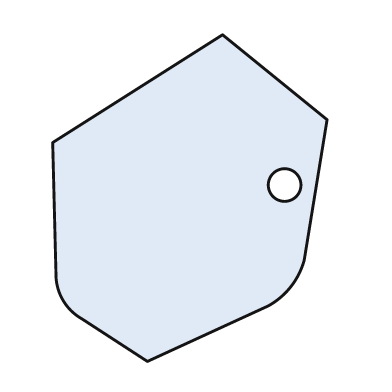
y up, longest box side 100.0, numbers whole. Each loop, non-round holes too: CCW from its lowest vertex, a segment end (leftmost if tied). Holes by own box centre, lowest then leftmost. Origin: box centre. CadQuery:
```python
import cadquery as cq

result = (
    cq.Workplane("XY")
    .moveTo(-13.0, -50.0)
    .lineTo(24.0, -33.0)
    .threePointArc((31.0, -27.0), (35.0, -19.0))
    .lineTo(42.0, 24.0)
    .lineTo(10.0, 50.0)
    .lineTo(-42.0, 17.0)
    .lineTo(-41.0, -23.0)
    .threePointArc((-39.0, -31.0), (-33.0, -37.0))
    .close()
    .moveTo(29.0, 4.0)
    .circle(5.0)
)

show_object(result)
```